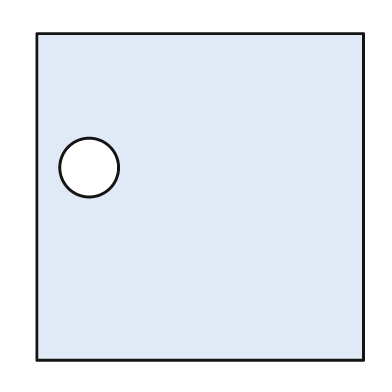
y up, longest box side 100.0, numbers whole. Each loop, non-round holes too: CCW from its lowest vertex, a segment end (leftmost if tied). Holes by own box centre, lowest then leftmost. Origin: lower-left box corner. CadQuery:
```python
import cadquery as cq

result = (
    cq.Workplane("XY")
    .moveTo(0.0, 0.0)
    .lineTo(100.0, 0.0)
    .lineTo(100.0, 100.0)
    .lineTo(0.0, 100.0)
    .close()
    .moveTo(16.0, 59.0)
    .circle(9.0)
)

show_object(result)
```